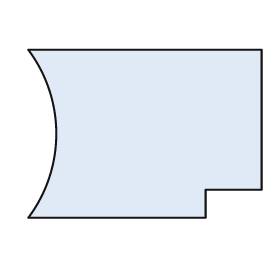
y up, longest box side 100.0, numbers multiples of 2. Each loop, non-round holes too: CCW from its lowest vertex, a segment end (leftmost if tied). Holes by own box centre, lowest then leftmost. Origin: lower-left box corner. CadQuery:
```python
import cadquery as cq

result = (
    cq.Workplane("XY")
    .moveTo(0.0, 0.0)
    .lineTo(76.0, 0.0)
    .lineTo(76.0, 12.0)
    .lineTo(100.0, 12.0)
    .lineTo(100.0, 72.0)
    .lineTo(0.0, 72.0)
    .threePointArc((12.0, 36.0), (0.0, 0.0))
    .close()
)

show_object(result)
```